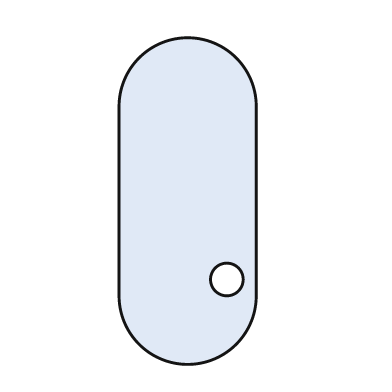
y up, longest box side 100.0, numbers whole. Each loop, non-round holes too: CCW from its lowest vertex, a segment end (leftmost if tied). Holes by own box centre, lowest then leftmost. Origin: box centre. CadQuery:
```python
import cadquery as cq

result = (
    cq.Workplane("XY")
    .moveTo(-21.0, -29.0)
    .threePointArc((0.0, -50.0), (21.0, -29.0))
    .lineTo(21.0, 29.0)
    .threePointArc((0.0, 50.0), (-21.0, 29.0))
    .close()
    .moveTo(12.0, -24.0)
    .circle(5.0)
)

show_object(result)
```